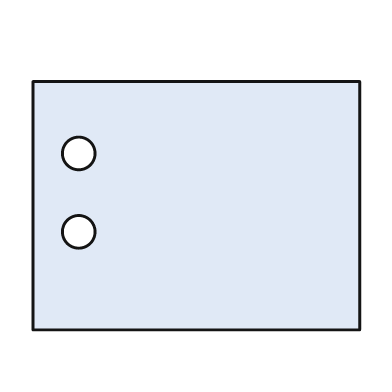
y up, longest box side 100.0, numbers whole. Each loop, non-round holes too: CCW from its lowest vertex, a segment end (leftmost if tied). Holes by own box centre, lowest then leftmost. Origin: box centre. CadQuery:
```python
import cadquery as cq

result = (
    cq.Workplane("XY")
    .moveTo(-50.0, -38.0)
    .lineTo(50.0, -38.0)
    .lineTo(50.0, 38.0)
    .lineTo(-50.0, 38.0)
    .close()
    .moveTo(-36.0, -8.0)
    .circle(5.0)
    .moveTo(-36.0, 16.0)
    .circle(5.0)
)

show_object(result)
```